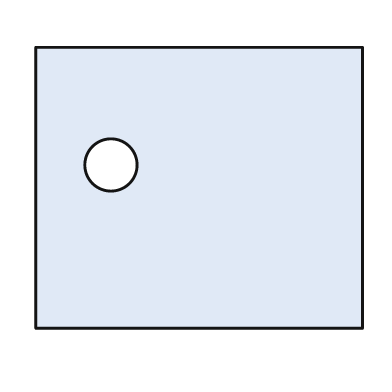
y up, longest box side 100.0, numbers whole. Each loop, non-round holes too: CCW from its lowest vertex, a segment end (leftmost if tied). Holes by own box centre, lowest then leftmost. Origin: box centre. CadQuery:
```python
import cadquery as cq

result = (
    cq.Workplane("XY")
    .moveTo(-50.0, -43.0)
    .lineTo(50.0, -43.0)
    .lineTo(50.0, 43.0)
    .lineTo(-50.0, 43.0)
    .close()
    .moveTo(-27.0, 7.0)
    .circle(8.0)
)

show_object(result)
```